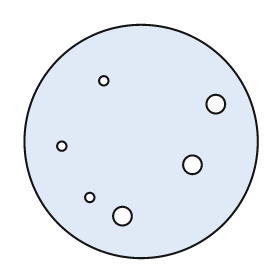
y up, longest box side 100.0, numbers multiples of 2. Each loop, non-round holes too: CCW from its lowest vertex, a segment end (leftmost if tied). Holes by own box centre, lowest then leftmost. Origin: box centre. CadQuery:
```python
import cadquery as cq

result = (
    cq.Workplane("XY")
    .moveTo(0.0, 0.0)
    .circle(50.0)
    .moveTo(-8.0, -32.0)
    .circle(4.0)
    .moveTo(-22.0, -24.0)
    .circle(2.0)
    .moveTo(22.0, -10.0)
    .circle(4.0)
    .moveTo(-34.0, -2.0)
    .circle(2.0)
    .moveTo(32.0, 16.0)
    .circle(4.0)
    .moveTo(-16.0, 26.0)
    .circle(2.0)
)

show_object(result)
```